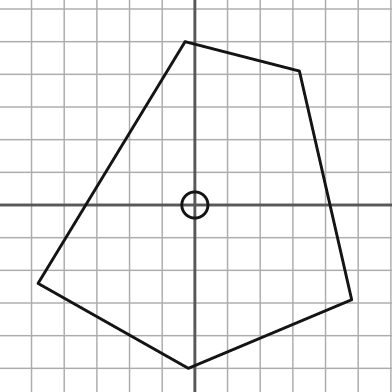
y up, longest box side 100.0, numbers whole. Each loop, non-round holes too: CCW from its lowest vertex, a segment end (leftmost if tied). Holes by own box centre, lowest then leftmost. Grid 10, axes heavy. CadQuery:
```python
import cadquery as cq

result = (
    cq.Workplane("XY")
    .moveTo(-2.0, -50.0)
    .lineTo(48.0, -29.0)
    .lineTo(32.0, 41.0)
    .lineTo(-3.0, 50.0)
    .lineTo(-48.0, -24.0)
    .close()
    .moveTo(0.0, 0.0)
    .circle(4.0)
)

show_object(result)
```